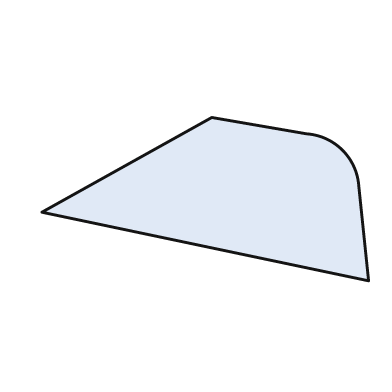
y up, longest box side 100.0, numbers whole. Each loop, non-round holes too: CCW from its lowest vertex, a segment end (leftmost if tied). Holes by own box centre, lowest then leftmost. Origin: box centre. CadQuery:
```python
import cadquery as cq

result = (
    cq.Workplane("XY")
    .moveTo(50.0, -25.0)
    .lineTo(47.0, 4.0)
    .threePointArc((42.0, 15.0), (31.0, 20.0))
    .lineTo(2.0, 25.0)
    .lineTo(-50.0, -4.0)
    .close()
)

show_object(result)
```